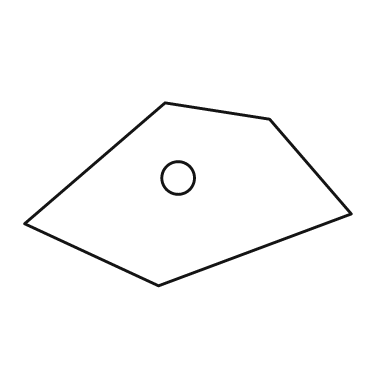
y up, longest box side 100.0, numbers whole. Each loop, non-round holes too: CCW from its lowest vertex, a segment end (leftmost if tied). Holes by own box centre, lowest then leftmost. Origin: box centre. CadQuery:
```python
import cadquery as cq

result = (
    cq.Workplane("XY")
    .moveTo(-9.0, -28.0)
    .lineTo(50.0, -6.0)
    .lineTo(25.0, 23.0)
    .lineTo(-7.0, 28.0)
    .lineTo(-50.0, -9.0)
    .close()
    .moveTo(-3.0, 5.0)
    .circle(5.0)
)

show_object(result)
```